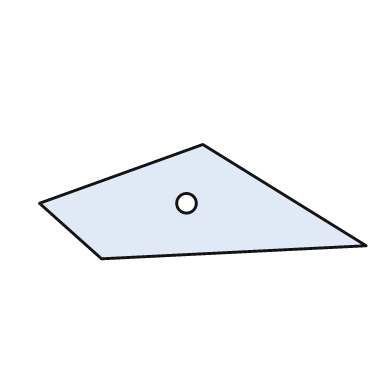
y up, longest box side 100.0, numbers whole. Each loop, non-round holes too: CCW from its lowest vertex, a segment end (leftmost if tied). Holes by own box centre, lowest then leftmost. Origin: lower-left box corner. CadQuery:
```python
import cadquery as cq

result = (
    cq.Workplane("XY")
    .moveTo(19.0, 0.0)
    .lineTo(100.0, 4.0)
    .lineTo(50.0, 35.0)
    .lineTo(0.0, 17.0)
    .close()
    .moveTo(45.0, 17.0)
    .circle(3.0)
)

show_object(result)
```